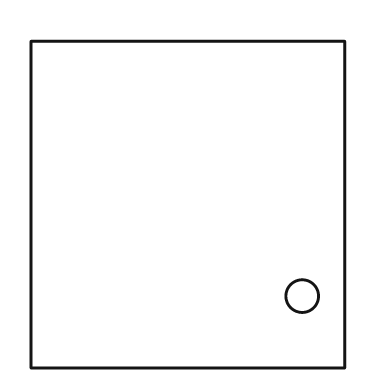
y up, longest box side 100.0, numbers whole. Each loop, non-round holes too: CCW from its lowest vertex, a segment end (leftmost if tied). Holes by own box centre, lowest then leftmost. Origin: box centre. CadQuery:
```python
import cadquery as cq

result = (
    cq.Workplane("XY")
    .moveTo(-48.0, -50.0)
    .lineTo(48.0, -50.0)
    .lineTo(48.0, 50.0)
    .lineTo(-48.0, 50.0)
    .close()
    .moveTo(35.0, -28.0)
    .circle(5.0)
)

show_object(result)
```